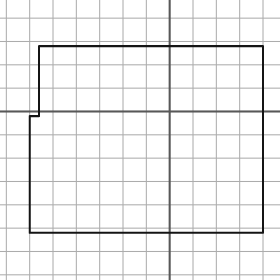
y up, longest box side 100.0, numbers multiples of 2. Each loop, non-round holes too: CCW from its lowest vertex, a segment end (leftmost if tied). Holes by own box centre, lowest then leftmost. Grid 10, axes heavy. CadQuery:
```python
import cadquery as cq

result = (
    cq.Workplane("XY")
    .moveTo(-60.0, -52.0)
    .lineTo(40.0, -52.0)
    .lineTo(40.0, 28.0)
    .lineTo(-56.0, 28.0)
    .lineTo(-56.0, -2.0)
    .lineTo(-60.0, -2.0)
    .close()
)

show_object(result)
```